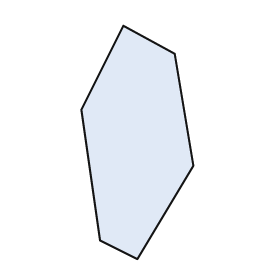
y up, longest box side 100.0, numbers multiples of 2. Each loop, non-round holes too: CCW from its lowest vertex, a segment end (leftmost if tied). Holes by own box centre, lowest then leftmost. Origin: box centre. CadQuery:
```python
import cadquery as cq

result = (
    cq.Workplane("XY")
    .moveTo(0.0, -50.0)
    .lineTo(24.0, -10.0)
    .lineTo(16.0, 38.0)
    .lineTo(-6.0, 50.0)
    .lineTo(-24.0, 14.0)
    .lineTo(-16.0, -42.0)
    .close()
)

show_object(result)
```